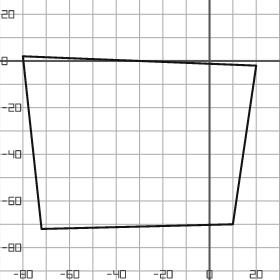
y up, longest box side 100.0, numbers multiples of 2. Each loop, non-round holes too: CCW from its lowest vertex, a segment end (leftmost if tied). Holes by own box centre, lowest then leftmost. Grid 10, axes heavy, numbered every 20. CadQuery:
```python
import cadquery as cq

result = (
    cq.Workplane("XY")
    .moveTo(-72.0, -72.0)
    .lineTo(10.0, -70.0)
    .lineTo(20.0, -2.0)
    .lineTo(-80.0, 2.0)
    .close()
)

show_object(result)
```